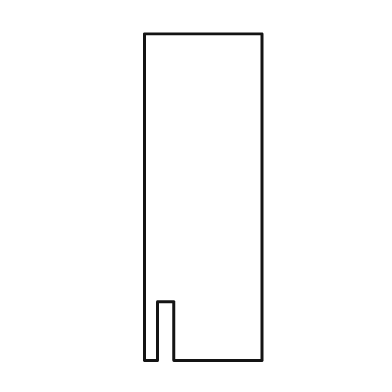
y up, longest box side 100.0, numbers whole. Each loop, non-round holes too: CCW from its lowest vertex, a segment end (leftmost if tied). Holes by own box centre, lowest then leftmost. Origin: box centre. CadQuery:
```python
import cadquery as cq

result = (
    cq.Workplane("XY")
    .moveTo(-18.0, -50.0)
    .lineTo(-14.0, -50.0)
    .lineTo(-14.0, -32.0)
    .lineTo(-9.0, -32.0)
    .lineTo(-9.0, -50.0)
    .lineTo(18.0, -50.0)
    .lineTo(18.0, 50.0)
    .lineTo(-18.0, 50.0)
    .close()
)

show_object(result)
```